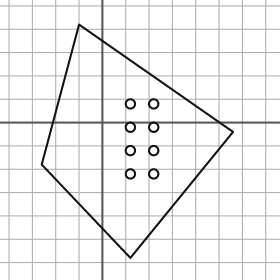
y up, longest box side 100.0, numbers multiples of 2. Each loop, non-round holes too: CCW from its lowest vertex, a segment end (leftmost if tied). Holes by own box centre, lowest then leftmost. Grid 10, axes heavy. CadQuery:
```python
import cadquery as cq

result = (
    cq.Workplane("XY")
    .moveTo(12.0, -58.0)
    .lineTo(56.0, -4.0)
    .lineTo(-10.0, 42.0)
    .lineTo(-26.0, -18.0)
    .close()
    .moveTo(12.0, -22.0)
    .circle(2.0)
    .moveTo(22.0, -22.0)
    .circle(2.0)
    .moveTo(12.0, -12.0)
    .circle(2.0)
    .moveTo(22.0, -12.0)
    .circle(2.0)
    .moveTo(12.0, -2.0)
    .circle(2.0)
    .moveTo(22.0, -2.0)
    .circle(2.0)
    .moveTo(12.0, 8.0)
    .circle(2.0)
    .moveTo(22.0, 8.0)
    .circle(2.0)
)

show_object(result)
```